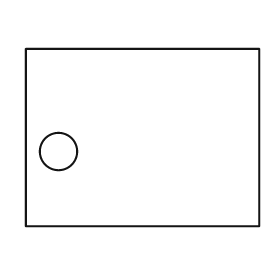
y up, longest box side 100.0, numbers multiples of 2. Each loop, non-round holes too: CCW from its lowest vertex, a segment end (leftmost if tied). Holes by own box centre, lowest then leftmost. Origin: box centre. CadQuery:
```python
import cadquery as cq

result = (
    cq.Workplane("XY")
    .moveTo(-50.0, -38.0)
    .lineTo(50.0, -38.0)
    .lineTo(50.0, 38.0)
    .lineTo(-50.0, 38.0)
    .close()
    .moveTo(-36.0, -6.0)
    .circle(8.0)
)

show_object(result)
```